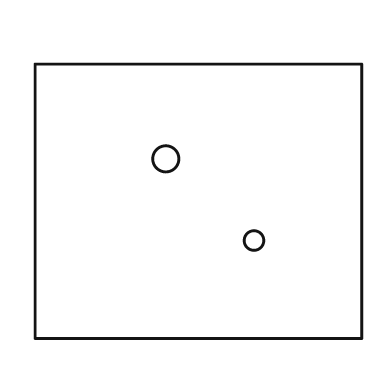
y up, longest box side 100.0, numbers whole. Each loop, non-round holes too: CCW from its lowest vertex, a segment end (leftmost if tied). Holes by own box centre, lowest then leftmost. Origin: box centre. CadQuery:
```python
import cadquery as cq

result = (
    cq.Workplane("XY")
    .moveTo(-50.0, -42.0)
    .lineTo(50.0, -42.0)
    .lineTo(50.0, 42.0)
    .lineTo(-50.0, 42.0)
    .close()
    .moveTo(17.0, -12.0)
    .circle(3.0)
    .moveTo(-10.0, 13.0)
    .circle(4.0)
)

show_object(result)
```